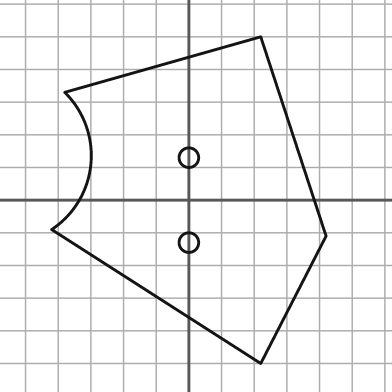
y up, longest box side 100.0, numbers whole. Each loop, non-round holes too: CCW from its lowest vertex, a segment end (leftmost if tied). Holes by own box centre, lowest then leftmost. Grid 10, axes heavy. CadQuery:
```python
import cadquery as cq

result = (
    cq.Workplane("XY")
    .moveTo(22.0, -50.0)
    .lineTo(42.0, -11.0)
    .lineTo(22.0, 50.0)
    .lineTo(-38.0, 33.0)
    .threePointArc((-30.0, 11.0), (-42.0, -9.0))
    .close()
    .moveTo(0.0, -13.0)
    .circle(3.0)
    .moveTo(0.0, 13.0)
    .circle(3.0)
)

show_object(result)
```